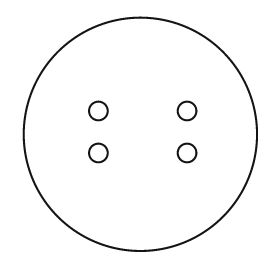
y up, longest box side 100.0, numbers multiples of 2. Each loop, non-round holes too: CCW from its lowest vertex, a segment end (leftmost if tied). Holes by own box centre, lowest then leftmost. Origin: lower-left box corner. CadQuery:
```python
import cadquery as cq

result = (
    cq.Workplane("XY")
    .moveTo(50.0, 50.0)
    .circle(50.0)
    .moveTo(32.0, 42.0)
    .circle(4.0)
    .moveTo(70.0, 42.0)
    .circle(4.0)
    .moveTo(32.0, 60.0)
    .circle(4.0)
    .moveTo(70.0, 60.0)
    .circle(4.0)
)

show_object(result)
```